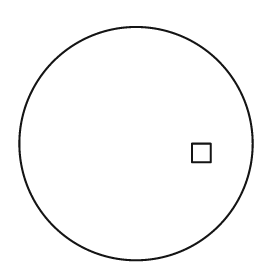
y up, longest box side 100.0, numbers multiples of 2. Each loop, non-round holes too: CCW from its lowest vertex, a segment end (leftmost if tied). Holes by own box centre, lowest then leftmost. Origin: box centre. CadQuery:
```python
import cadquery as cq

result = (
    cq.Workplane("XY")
    .moveTo(0.0, 0.0)
    .circle(50.0)
    .moveTo(24.0, -8.0)
    .lineTo(32.0, -8.0)
    .lineTo(32.0, 0.0)
    .lineTo(24.0, 0.0)
    .close()
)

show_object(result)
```